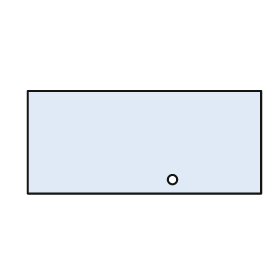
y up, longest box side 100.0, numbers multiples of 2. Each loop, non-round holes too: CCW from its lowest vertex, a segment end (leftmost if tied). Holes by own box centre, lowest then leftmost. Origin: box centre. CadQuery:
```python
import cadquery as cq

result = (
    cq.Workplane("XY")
    .moveTo(-50.0, -22.0)
    .lineTo(50.0, -22.0)
    .lineTo(50.0, 22.0)
    .lineTo(-50.0, 22.0)
    .close()
    .moveTo(12.0, -16.0)
    .circle(2.0)
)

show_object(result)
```